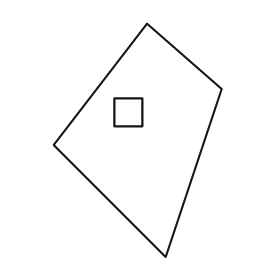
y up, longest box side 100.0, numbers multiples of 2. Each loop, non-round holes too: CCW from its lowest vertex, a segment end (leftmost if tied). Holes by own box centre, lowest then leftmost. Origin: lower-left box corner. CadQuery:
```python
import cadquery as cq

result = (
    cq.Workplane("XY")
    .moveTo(48.0, 0.0)
    .lineTo(72.0, 72.0)
    .lineTo(40.0, 100.0)
    .lineTo(0.0, 48.0)
    .close()
    .moveTo(26.0, 56.0)
    .lineTo(38.0, 56.0)
    .lineTo(38.0, 68.0)
    .lineTo(26.0, 68.0)
    .close()
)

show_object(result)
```